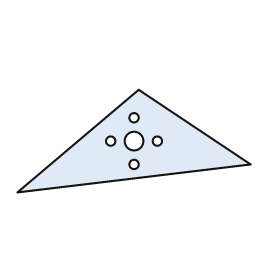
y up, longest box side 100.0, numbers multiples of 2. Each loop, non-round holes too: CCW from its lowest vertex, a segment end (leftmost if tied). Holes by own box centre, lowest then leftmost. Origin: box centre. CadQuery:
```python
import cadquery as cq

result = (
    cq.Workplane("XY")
    .moveTo(-50.0, -22.0)
    .lineTo(50.0, -10.0)
    .lineTo(2.0, 22.0)
    .close()
    .moveTo(0.0, -10.0)
    .circle(2.0)
    .moveTo(-10.0, 0.0)
    .circle(2.0)
    .moveTo(0.0, 0.0)
    .circle(4.0)
    .moveTo(10.0, 0.0)
    .circle(2.0)
    .moveTo(0.0, 10.0)
    .circle(2.0)
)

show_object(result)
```